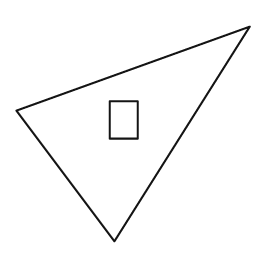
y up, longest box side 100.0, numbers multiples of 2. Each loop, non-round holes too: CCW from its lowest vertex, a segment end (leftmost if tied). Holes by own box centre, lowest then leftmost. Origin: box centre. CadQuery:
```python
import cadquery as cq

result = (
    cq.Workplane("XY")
    .moveTo(-8.0, -46.0)
    .lineTo(50.0, 46.0)
    .lineTo(-50.0, 10.0)
    .close()
    .moveTo(-10.0, -2.0)
    .lineTo(2.0, -2.0)
    .lineTo(2.0, 14.0)
    .lineTo(-10.0, 14.0)
    .close()
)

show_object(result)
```